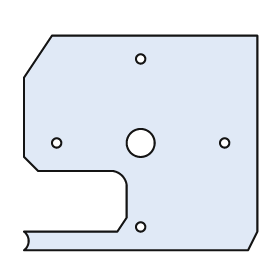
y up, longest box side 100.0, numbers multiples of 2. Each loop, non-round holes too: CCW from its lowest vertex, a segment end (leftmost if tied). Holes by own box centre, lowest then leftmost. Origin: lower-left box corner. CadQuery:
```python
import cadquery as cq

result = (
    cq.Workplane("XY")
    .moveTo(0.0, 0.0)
    .lineTo(96.0, 0.0)
    .lineTo(100.0, 8.0)
    .lineTo(100.0, 92.0)
    .lineTo(12.0, 92.0)
    .lineTo(0.0, 74.0)
    .lineTo(0.0, 40.0)
    .lineTo(6.0, 34.0)
    .lineTo(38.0, 34.0)
    .threePointArc((42.0, 32.0), (44.0, 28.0))
    .lineTo(44.0, 14.0)
    .lineTo(40.0, 8.0)
    .lineTo(0.0, 8.0)
    .threePointArc((2.0, 4.0), (0.0, 0.0))
    .close()
    .moveTo(50.0, 10.0)
    .circle(2.0)
    .moveTo(14.0, 46.0)
    .circle(2.0)
    .moveTo(50.0, 46.0)
    .circle(6.0)
    .moveTo(86.0, 46.0)
    .circle(2.0)
    .moveTo(50.0, 82.0)
    .circle(2.0)
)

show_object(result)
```